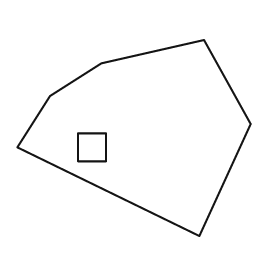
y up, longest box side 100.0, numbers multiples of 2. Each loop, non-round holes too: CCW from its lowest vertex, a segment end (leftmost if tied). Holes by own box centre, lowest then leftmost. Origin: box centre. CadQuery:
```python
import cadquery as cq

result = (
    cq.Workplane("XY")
    .moveTo(28.0, -42.0)
    .lineTo(50.0, 6.0)
    .lineTo(30.0, 42.0)
    .lineTo(-14.0, 32.0)
    .lineTo(-36.0, 18.0)
    .lineTo(-50.0, -4.0)
    .close()
    .moveTo(-24.0, -10.0)
    .lineTo(-12.0, -10.0)
    .lineTo(-12.0, 2.0)
    .lineTo(-24.0, 2.0)
    .close()
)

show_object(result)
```